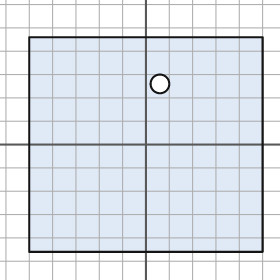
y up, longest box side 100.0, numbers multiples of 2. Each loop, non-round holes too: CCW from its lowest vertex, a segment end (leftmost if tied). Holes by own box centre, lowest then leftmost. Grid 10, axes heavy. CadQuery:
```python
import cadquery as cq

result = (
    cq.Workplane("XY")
    .moveTo(-50.0, -46.0)
    .lineTo(50.0, -46.0)
    .lineTo(50.0, 46.0)
    .lineTo(-50.0, 46.0)
    .close()
    .moveTo(6.0, 26.0)
    .circle(4.0)
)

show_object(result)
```